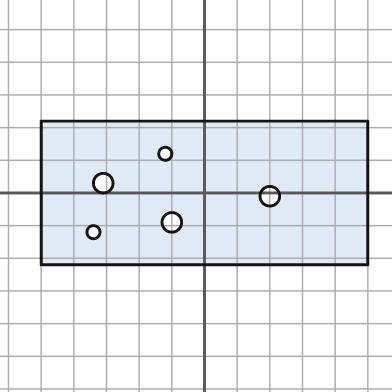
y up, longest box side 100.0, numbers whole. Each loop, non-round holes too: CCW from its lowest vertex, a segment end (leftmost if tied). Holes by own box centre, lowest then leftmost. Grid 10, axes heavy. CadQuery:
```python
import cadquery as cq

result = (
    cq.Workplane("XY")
    .moveTo(-50.0, -22.0)
    .lineTo(50.0, -22.0)
    .lineTo(50.0, 22.0)
    .lineTo(-50.0, 22.0)
    .close()
    .moveTo(-34.0, -12.0)
    .circle(2.0)
    .moveTo(-10.0, -9.0)
    .circle(3.0)
    .moveTo(20.0, -1.0)
    .circle(3.0)
    .moveTo(-31.0, 3.0)
    .circle(3.0)
    .moveTo(-12.0, 12.0)
    .circle(2.0)
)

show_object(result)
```